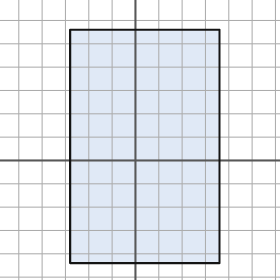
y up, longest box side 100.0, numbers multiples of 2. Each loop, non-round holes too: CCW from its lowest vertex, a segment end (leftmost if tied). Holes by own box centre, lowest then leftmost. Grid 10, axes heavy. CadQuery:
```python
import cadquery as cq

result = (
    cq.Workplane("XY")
    .moveTo(-28.0, -44.0)
    .lineTo(36.0, -44.0)
    .lineTo(36.0, 56.0)
    .lineTo(-28.0, 56.0)
    .close()
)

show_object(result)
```